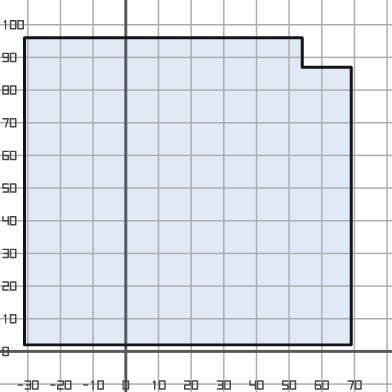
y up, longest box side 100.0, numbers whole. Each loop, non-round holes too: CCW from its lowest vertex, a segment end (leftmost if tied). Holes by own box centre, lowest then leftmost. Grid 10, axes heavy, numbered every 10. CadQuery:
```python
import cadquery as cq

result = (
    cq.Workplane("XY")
    .moveTo(-31.0, 2.0)
    .lineTo(69.0, 2.0)
    .lineTo(69.0, 87.0)
    .lineTo(54.0, 87.0)
    .lineTo(54.0, 96.0)
    .lineTo(-31.0, 96.0)
    .close()
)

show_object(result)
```